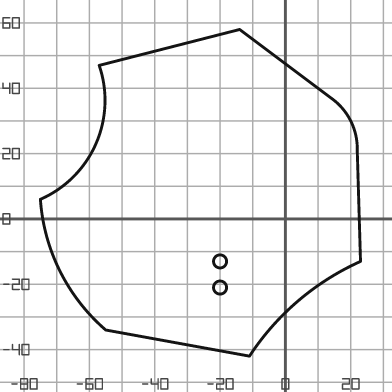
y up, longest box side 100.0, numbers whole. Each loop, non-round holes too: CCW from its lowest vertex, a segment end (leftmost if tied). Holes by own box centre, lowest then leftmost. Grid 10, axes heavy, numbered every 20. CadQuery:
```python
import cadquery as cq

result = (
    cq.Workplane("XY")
    .moveTo(-11.0, -42.0)
    .threePointArc((4.0, -25.0), (23.0, -13.0))
    .lineTo(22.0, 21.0)
    .threePointArc((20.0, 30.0), (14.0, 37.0))
    .lineTo(-14.0, 58.0)
    .lineTo(-57.0, 47.0)
    .threePointArc((-58.0, 23.0), (-75.0, 6.0))
    .threePointArc((-69.0, -16.0), (-55.0, -34.0))
    .close()
    .moveTo(-20.0, -21.0)
    .circle(2.0)
    .moveTo(-20.0, -13.0)
    .circle(2.0)
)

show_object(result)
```